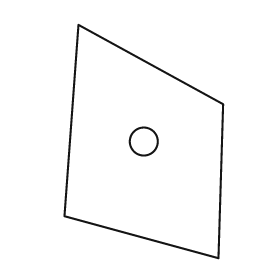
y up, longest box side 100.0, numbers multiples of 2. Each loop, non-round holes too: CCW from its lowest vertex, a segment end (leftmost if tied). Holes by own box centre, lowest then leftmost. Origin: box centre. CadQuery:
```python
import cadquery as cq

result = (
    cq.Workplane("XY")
    .moveTo(32.0, -50.0)
    .lineTo(34.0, 16.0)
    .lineTo(-28.0, 50.0)
    .lineTo(-34.0, -32.0)
    .close()
    .moveTo(0.0, 0.0)
    .circle(6.0)
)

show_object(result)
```